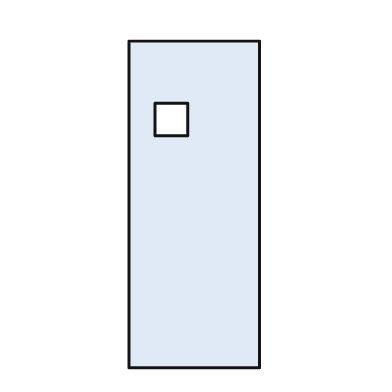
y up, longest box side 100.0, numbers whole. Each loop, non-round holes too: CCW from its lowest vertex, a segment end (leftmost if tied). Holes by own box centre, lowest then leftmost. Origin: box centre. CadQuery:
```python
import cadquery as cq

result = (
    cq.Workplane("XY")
    .moveTo(-20.0, -50.0)
    .lineTo(20.0, -50.0)
    .lineTo(20.0, 50.0)
    .lineTo(-20.0, 50.0)
    .close()
    .moveTo(-12.0, 21.0)
    .lineTo(-2.0, 21.0)
    .lineTo(-2.0, 31.0)
    .lineTo(-12.0, 31.0)
    .close()
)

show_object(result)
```